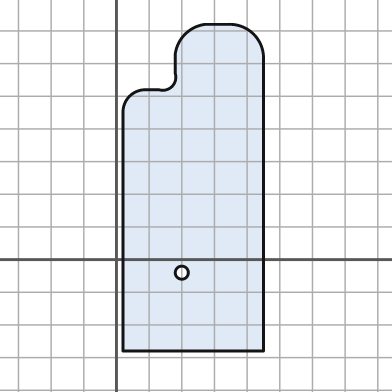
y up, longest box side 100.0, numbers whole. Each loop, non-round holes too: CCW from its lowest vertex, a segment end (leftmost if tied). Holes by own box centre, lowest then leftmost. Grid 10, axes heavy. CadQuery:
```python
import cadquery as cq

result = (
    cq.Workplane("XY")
    .moveTo(2.0, -28.0)
    .lineTo(45.0, -28.0)
    .lineTo(45.0, 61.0)
    .threePointArc((42.0, 69.0), (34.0, 72.0))
    .lineTo(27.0, 72.0)
    .threePointArc((21.0, 69.0), (18.0, 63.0))
    .lineTo(18.0, 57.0)
    .threePointArc((17.0, 53.0), (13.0, 52.0))
    .lineTo(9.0, 52.0)
    .threePointArc((4.0, 50.0), (2.0, 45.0))
    .close()
    .moveTo(20.0, -4.0)
    .circle(2.0)
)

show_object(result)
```